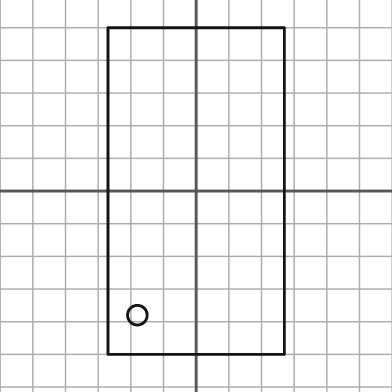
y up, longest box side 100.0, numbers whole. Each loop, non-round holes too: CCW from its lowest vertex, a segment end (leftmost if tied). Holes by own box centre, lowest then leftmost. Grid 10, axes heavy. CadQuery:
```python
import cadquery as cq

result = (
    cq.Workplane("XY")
    .moveTo(-27.0, -50.0)
    .lineTo(27.0, -50.0)
    .lineTo(27.0, 50.0)
    .lineTo(-27.0, 50.0)
    .close()
    .moveTo(-18.0, -38.0)
    .circle(3.0)
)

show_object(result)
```